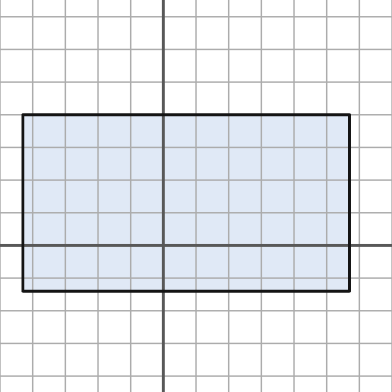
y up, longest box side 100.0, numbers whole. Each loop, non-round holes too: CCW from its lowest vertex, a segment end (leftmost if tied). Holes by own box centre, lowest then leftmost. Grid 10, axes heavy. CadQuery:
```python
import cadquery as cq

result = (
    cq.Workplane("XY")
    .moveTo(-43.0, -14.0)
    .lineTo(57.0, -14.0)
    .lineTo(57.0, 40.0)
    .lineTo(-43.0, 40.0)
    .close()
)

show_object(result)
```